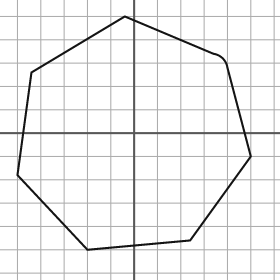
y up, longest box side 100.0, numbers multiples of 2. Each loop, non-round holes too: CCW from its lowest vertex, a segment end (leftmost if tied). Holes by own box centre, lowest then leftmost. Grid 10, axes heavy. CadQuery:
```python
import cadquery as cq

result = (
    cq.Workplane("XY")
    .moveTo(-20.0, -50.0)
    .lineTo(24.0, -46.0)
    .lineTo(50.0, -10.0)
    .lineTo(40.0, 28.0)
    .threePointArc((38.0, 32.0), (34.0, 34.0))
    .lineTo(-4.0, 50.0)
    .lineTo(-44.0, 26.0)
    .lineTo(-50.0, -18.0)
    .close()
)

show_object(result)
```